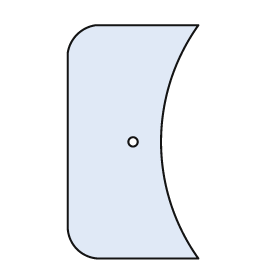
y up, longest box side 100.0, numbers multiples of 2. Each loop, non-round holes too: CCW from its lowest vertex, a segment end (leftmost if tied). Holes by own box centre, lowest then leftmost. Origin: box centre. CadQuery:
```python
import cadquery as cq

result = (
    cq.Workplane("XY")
    .moveTo(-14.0, -50.0)
    .lineTo(28.0, -50.0)
    .threePointArc((12.0, 0.0), (28.0, 50.0))
    .lineTo(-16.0, 50.0)
    .threePointArc((-24.0, 46.0), (-28.0, 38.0))
    .lineTo(-28.0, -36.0)
    .threePointArc((-24.0, -46.0), (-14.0, -50.0))
    .close()
    .moveTo(0.0, 0.0)
    .circle(2.0)
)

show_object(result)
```